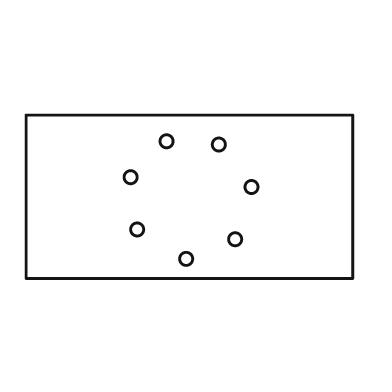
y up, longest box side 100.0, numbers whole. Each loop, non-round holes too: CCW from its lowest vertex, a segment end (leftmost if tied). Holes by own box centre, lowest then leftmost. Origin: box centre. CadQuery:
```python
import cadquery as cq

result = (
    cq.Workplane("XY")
    .moveTo(-50.0, -25.0)
    .lineTo(50.0, -25.0)
    .lineTo(50.0, 25.0)
    .lineTo(-50.0, 25.0)
    .close()
    .moveTo(-1.0, -19.0)
    .circle(2.0)
    .moveTo(14.0, -13.0)
    .circle(2.0)
    .moveTo(-16.0, -10.0)
    .circle(2.0)
    .moveTo(19.0, 3.0)
    .circle(2.0)
    .moveTo(-18.0, 6.0)
    .circle(2.0)
    .moveTo(9.0, 16.0)
    .circle(2.0)
    .moveTo(-7.0, 17.0)
    .circle(2.0)
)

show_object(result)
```